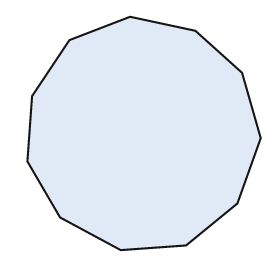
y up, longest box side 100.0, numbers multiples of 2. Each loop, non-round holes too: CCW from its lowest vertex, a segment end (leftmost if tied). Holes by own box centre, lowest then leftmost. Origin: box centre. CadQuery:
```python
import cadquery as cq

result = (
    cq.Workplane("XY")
    .moveTo(-10.0, -50.0)
    .lineTo(18.0, -48.0)
    .lineTo(40.0, -30.0)
    .lineTo(50.0, -2.0)
    .lineTo(42.0, 26.0)
    .lineTo(22.0, 44.0)
    .lineTo(-6.0, 50.0)
    .lineTo(-32.0, 40.0)
    .lineTo(-48.0, 16.0)
    .lineTo(-50.0, -12.0)
    .lineTo(-36.0, -36.0)
    .close()
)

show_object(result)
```